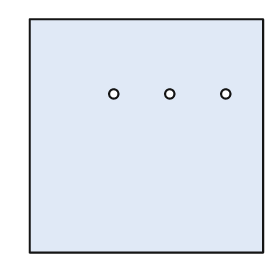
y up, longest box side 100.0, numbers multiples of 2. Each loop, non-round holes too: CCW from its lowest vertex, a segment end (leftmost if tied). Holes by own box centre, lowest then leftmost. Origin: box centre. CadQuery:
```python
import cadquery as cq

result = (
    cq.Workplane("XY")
    .moveTo(-50.0, -50.0)
    .lineTo(50.0, -50.0)
    .lineTo(50.0, 50.0)
    .lineTo(-50.0, 50.0)
    .close()
    .moveTo(-14.0, 18.0)
    .circle(2.0)
    .moveTo(10.0, 18.0)
    .circle(2.0)
    .moveTo(34.0, 18.0)
    .circle(2.0)
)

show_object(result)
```